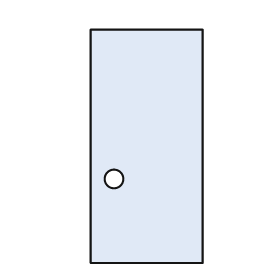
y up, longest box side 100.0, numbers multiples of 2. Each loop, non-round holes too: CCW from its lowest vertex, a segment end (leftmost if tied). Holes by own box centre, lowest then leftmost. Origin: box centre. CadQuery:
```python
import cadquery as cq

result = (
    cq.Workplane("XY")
    .moveTo(-24.0, -50.0)
    .lineTo(24.0, -50.0)
    .lineTo(24.0, 50.0)
    .lineTo(-24.0, 50.0)
    .close()
    .moveTo(-14.0, -14.0)
    .circle(4.0)
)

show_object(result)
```